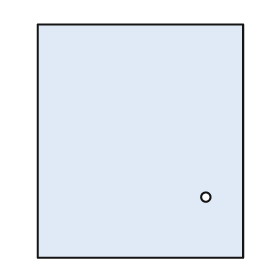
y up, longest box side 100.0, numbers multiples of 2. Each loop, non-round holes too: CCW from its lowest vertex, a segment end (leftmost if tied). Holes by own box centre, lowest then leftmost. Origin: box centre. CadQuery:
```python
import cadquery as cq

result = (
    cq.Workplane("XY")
    .moveTo(-44.0, -50.0)
    .lineTo(44.0, -50.0)
    .lineTo(44.0, 50.0)
    .lineTo(-44.0, 50.0)
    .close()
    .moveTo(28.0, -24.0)
    .circle(2.0)
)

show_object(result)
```